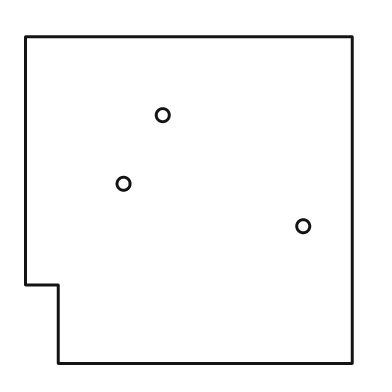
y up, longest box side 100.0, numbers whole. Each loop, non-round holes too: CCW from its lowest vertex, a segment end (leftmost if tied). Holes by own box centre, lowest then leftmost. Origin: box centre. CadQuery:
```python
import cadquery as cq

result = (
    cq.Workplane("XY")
    .moveTo(-40.0, -50.0)
    .lineTo(50.0, -50.0)
    .lineTo(50.0, 50.0)
    .lineTo(-50.0, 50.0)
    .lineTo(-50.0, -26.0)
    .lineTo(-40.0, -26.0)
    .close()
    .moveTo(35.0, -8.0)
    .circle(2.0)
    .moveTo(-20.0, 5.0)
    .circle(2.0)
    .moveTo(-8.0, 26.0)
    .circle(2.0)
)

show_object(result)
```